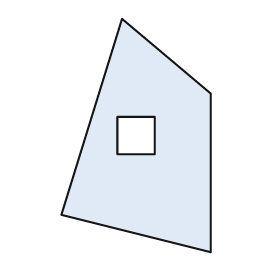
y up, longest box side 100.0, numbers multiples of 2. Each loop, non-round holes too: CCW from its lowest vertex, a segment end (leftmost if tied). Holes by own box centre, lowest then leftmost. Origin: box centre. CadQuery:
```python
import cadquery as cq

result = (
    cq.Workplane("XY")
    .moveTo(32.0, -50.0)
    .lineTo(32.0, 18.0)
    .lineTo(-6.0, 50.0)
    .lineTo(-32.0, -34.0)
    .close()
    .moveTo(-8.0, -8.0)
    .lineTo(8.0, -8.0)
    .lineTo(8.0, 8.0)
    .lineTo(-8.0, 8.0)
    .close()
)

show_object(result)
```